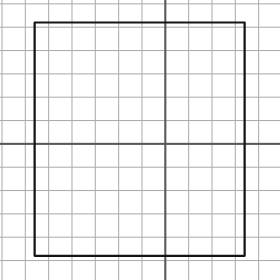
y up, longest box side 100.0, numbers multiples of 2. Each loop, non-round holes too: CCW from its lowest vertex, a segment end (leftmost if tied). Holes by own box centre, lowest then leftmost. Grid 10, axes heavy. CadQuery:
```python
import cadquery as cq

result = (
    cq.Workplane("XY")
    .moveTo(-56.0, -48.0)
    .lineTo(34.0, -48.0)
    .lineTo(34.0, 52.0)
    .lineTo(-56.0, 52.0)
    .close()
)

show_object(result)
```